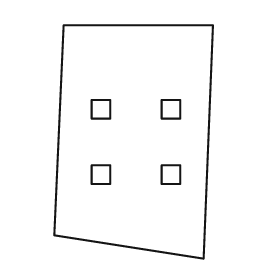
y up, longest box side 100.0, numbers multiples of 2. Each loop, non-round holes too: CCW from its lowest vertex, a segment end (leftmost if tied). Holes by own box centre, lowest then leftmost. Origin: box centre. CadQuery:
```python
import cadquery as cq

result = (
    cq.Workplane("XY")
    .moveTo(30.0, -50.0)
    .lineTo(34.0, 50.0)
    .lineTo(-30.0, 50.0)
    .lineTo(-34.0, -40.0)
    .close()
    .moveTo(-18.0, -18.0)
    .lineTo(-10.0, -18.0)
    .lineTo(-10.0, -10.0)
    .lineTo(-18.0, -10.0)
    .close()
    .moveTo(12.0, -18.0)
    .lineTo(20.0, -18.0)
    .lineTo(20.0, -10.0)
    .lineTo(12.0, -10.0)
    .close()
    .moveTo(-18.0, 10.0)
    .lineTo(-10.0, 10.0)
    .lineTo(-10.0, 18.0)
    .lineTo(-18.0, 18.0)
    .close()
    .moveTo(12.0, 10.0)
    .lineTo(20.0, 10.0)
    .lineTo(20.0, 18.0)
    .lineTo(12.0, 18.0)
    .close()
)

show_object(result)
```